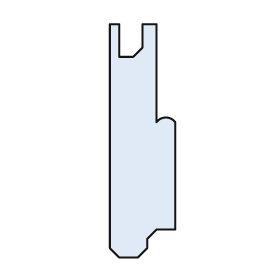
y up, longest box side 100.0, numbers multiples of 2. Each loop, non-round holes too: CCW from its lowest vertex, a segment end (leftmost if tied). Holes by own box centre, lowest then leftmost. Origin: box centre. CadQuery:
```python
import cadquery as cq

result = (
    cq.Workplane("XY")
    .moveTo(-10.0, -50.0)
    .lineTo(-2.0, -50.0)
    .lineTo(2.0, -46.0)
    .lineTo(2.0, -42.0)
    .lineTo(6.0, -38.0)
    .lineTo(14.0, -38.0)
    .lineTo(14.0, 8.0)
    .threePointArc((10.0, 10.0), (6.0, 8.0))
    .lineTo(6.0, 50.0)
    .lineTo(0.0, 50.0)
    .lineTo(0.0, 40.0)
    .lineTo(-4.0, 36.0)
    .lineTo(-10.0, 36.0)
    .lineTo(-10.0, 50.0)
    .lineTo(-14.0, 50.0)
    .lineTo(-14.0, -46.0)
    .close()
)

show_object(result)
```